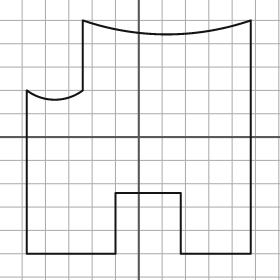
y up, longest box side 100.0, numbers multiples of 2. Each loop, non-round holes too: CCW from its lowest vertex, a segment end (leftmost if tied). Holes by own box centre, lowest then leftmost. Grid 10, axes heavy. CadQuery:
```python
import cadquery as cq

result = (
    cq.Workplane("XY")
    .moveTo(-48.0, -50.0)
    .lineTo(-10.0, -50.0)
    .lineTo(-10.0, -24.0)
    .lineTo(18.0, -24.0)
    .lineTo(18.0, -50.0)
    .lineTo(48.0, -50.0)
    .lineTo(48.0, 50.0)
    .threePointArc((12.0, 44.0), (-24.0, 50.0))
    .lineTo(-24.0, 20.0)
    .threePointArc((-36.0, 16.0), (-48.0, 20.0))
    .close()
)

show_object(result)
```